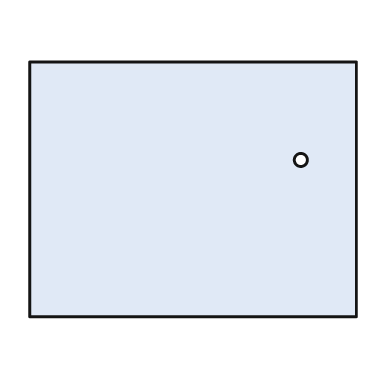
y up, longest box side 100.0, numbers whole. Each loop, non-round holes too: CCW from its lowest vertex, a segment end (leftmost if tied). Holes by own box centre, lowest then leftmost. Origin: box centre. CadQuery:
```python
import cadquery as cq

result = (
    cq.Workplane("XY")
    .moveTo(-50.0, -39.0)
    .lineTo(50.0, -39.0)
    .lineTo(50.0, 39.0)
    .lineTo(-50.0, 39.0)
    .close()
    .moveTo(33.0, 9.0)
    .circle(2.0)
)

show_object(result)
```